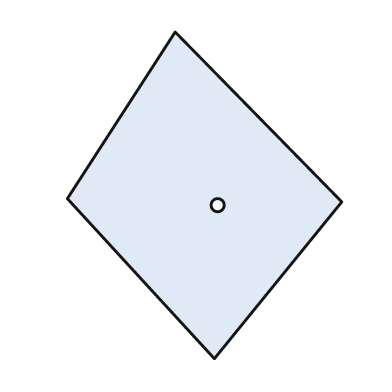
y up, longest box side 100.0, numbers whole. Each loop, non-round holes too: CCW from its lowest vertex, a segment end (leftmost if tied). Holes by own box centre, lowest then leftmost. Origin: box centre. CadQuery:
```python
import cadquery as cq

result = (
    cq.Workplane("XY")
    .moveTo(3.0, -50.0)
    .lineTo(42.0, -2.0)
    .lineTo(-9.0, 50.0)
    .lineTo(-42.0, -1.0)
    .close()
    .moveTo(4.0, -3.0)
    .circle(2.0)
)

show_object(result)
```